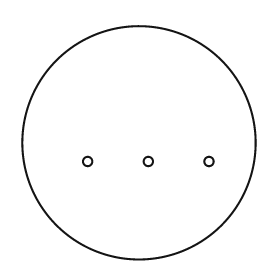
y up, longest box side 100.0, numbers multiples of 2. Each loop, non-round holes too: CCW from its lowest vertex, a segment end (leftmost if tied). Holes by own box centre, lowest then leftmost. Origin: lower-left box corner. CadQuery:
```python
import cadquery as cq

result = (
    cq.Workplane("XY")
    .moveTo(50.0, 50.0)
    .circle(50.0)
    .moveTo(28.0, 42.0)
    .circle(2.0)
    .moveTo(54.0, 42.0)
    .circle(2.0)
    .moveTo(80.0, 42.0)
    .circle(2.0)
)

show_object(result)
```